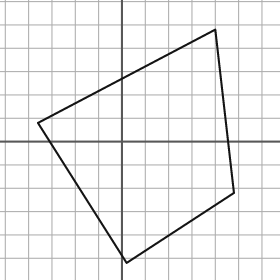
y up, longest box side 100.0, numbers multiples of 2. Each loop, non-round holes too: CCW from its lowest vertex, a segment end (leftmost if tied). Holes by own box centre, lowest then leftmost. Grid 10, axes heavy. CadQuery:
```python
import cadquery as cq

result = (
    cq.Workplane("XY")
    .moveTo(2.0, -52.0)
    .lineTo(48.0, -22.0)
    .lineTo(40.0, 48.0)
    .lineTo(-36.0, 8.0)
    .close()
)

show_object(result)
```